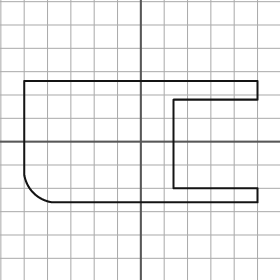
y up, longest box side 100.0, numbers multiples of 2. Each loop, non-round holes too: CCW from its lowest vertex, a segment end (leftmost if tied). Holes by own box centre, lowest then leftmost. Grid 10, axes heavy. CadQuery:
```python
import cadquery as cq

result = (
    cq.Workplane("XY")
    .moveTo(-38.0, -26.0)
    .lineTo(50.0, -26.0)
    .lineTo(50.0, -20.0)
    .lineTo(14.0, -20.0)
    .lineTo(14.0, 18.0)
    .lineTo(50.0, 18.0)
    .lineTo(50.0, 26.0)
    .lineTo(-50.0, 26.0)
    .lineTo(-50.0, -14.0)
    .threePointArc((-46.0, -22.0), (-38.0, -26.0))
    .close()
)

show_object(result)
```